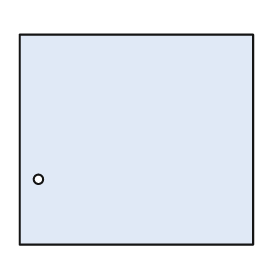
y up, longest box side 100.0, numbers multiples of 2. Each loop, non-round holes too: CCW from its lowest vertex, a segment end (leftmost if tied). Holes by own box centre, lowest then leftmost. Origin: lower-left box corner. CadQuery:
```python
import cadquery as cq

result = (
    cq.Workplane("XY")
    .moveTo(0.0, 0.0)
    .lineTo(100.0, 0.0)
    .lineTo(100.0, 90.0)
    .lineTo(0.0, 90.0)
    .close()
    .moveTo(8.0, 28.0)
    .circle(2.0)
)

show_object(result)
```